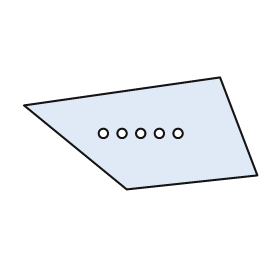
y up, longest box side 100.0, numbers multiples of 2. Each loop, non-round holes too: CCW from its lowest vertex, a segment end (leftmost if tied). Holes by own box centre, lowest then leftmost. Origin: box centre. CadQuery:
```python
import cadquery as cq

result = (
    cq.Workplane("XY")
    .moveTo(-6.0, -24.0)
    .lineTo(50.0, -18.0)
    .lineTo(34.0, 24.0)
    .lineTo(-50.0, 12.0)
    .close()
    .moveTo(-16.0, 0.0)
    .circle(2.0)
    .moveTo(-8.0, 0.0)
    .circle(2.0)
    .moveTo(0.0, 0.0)
    .circle(2.0)
    .moveTo(8.0, 0.0)
    .circle(2.0)
    .moveTo(16.0, 0.0)
    .circle(2.0)
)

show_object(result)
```